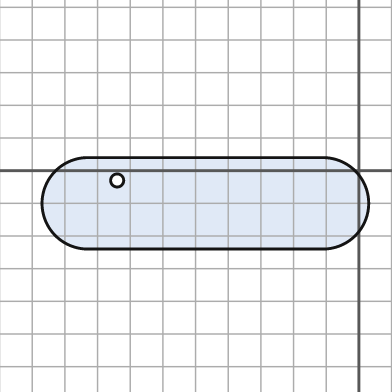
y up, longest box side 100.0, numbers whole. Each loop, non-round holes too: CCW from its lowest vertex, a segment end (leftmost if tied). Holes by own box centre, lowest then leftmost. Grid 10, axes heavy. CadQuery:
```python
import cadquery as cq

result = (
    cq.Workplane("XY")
    .moveTo(-83.0, -24.0)
    .lineTo(-11.0, -24.0)
    .threePointArc((3.0, -10.0), (-11.0, 4.0))
    .lineTo(-83.0, 4.0)
    .threePointArc((-97.0, -10.0), (-83.0, -24.0))
    .close()
    .moveTo(-74.0, -3.0)
    .circle(2.0)
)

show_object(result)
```